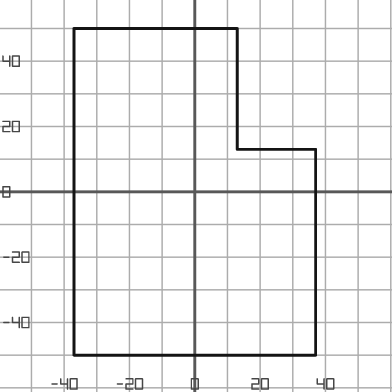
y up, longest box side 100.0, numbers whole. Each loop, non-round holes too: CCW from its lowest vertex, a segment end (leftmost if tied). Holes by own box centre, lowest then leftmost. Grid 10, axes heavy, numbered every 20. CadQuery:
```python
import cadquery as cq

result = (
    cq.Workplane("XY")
    .moveTo(-37.0, -50.0)
    .lineTo(37.0, -50.0)
    .lineTo(37.0, 13.0)
    .lineTo(13.0, 13.0)
    .lineTo(13.0, 50.0)
    .lineTo(-37.0, 50.0)
    .close()
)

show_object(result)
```